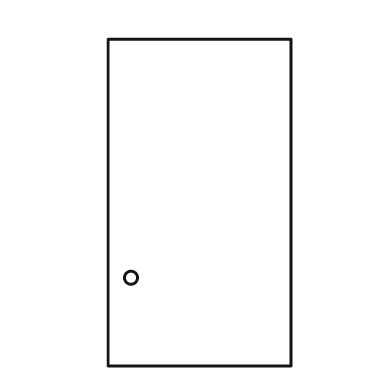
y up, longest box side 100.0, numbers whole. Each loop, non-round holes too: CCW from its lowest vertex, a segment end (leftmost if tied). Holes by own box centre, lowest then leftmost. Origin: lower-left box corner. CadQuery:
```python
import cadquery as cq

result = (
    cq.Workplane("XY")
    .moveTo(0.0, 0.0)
    .lineTo(56.0, 0.0)
    .lineTo(56.0, 100.0)
    .lineTo(0.0, 100.0)
    .close()
    .moveTo(7.0, 27.0)
    .circle(2.0)
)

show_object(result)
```